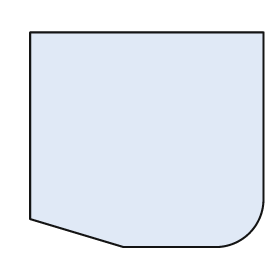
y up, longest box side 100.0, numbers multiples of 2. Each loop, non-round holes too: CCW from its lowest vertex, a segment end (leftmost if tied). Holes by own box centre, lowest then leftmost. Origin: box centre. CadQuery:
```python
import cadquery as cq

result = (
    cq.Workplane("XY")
    .moveTo(-10.0, -46.0)
    .lineTo(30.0, -46.0)
    .threePointArc((44.0, -40.0), (50.0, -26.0))
    .lineTo(50.0, 46.0)
    .lineTo(-50.0, 46.0)
    .lineTo(-50.0, -34.0)
    .close()
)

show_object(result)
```